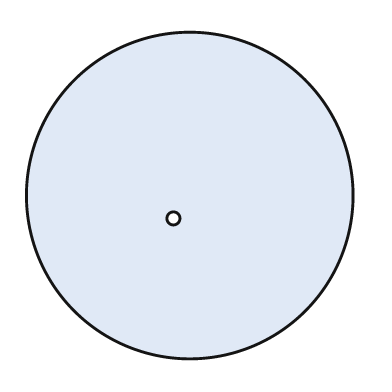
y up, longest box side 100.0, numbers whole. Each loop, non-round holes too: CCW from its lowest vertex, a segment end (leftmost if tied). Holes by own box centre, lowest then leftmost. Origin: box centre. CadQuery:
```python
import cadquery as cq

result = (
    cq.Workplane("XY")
    .moveTo(0.0, 0.0)
    .circle(50.0)
    .moveTo(-5.0, -7.0)
    .circle(2.0)
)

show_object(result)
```